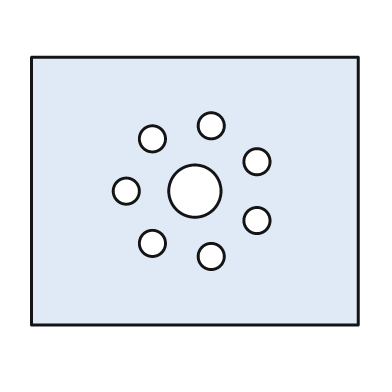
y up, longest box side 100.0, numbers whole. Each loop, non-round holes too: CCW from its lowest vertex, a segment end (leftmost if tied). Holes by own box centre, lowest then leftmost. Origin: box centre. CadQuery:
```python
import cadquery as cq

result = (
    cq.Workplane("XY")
    .moveTo(-50.0, -41.0)
    .lineTo(50.0, -41.0)
    .lineTo(50.0, 41.0)
    .lineTo(-50.0, 41.0)
    .close()
    .moveTo(5.0, -20.0)
    .circle(4.0)
    .moveTo(-13.0, -16.0)
    .circle(4.0)
    .moveTo(19.0, -9.0)
    .circle(4.0)
    .moveTo(-21.0, 0.0)
    .circle(4.0)
    .moveTo(0.0, 0.0)
    .circle(8.0)
    .moveTo(19.0, 9.0)
    .circle(4.0)
    .moveTo(-13.0, 16.0)
    .circle(4.0)
    .moveTo(5.0, 20.0)
    .circle(4.0)
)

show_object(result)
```